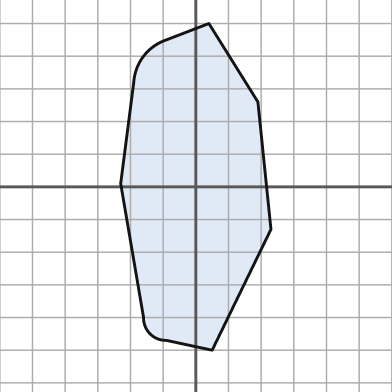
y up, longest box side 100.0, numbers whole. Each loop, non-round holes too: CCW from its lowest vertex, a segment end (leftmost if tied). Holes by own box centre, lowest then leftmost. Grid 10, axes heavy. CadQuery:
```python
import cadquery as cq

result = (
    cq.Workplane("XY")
    .moveTo(5.0, -50.0)
    .lineTo(23.0, -13.0)
    .lineTo(19.0, 26.0)
    .lineTo(4.0, 50.0)
    .lineTo(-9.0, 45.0)
    .threePointArc((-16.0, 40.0), (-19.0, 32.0))
    .lineTo(-23.0, 1.0)
    .lineTo(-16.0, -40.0)
    .threePointArc((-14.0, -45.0), (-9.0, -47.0))
    .close()
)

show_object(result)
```